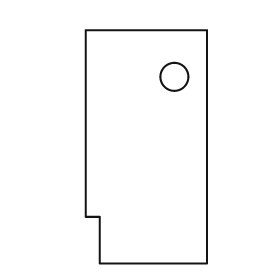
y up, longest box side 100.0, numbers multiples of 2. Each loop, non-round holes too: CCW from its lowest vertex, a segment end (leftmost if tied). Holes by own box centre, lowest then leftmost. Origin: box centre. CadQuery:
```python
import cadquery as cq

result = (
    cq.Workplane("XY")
    .moveTo(-20.0, -50.0)
    .lineTo(26.0, -50.0)
    .lineTo(26.0, 50.0)
    .lineTo(-26.0, 50.0)
    .lineTo(-26.0, -30.0)
    .lineTo(-20.0, -30.0)
    .close()
    .moveTo(12.0, 30.0)
    .circle(6.0)
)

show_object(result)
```